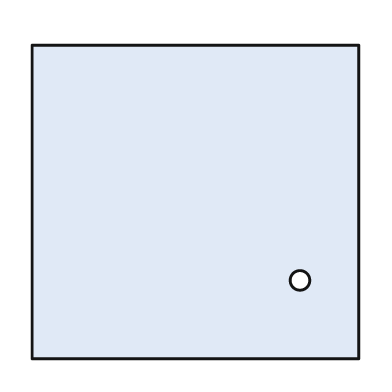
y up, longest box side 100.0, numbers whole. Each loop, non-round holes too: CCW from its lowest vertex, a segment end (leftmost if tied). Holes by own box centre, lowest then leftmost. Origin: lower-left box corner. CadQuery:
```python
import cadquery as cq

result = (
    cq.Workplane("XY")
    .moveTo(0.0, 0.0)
    .lineTo(100.0, 0.0)
    .lineTo(100.0, 96.0)
    .lineTo(0.0, 96.0)
    .close()
    .moveTo(82.0, 24.0)
    .circle(3.0)
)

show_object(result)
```